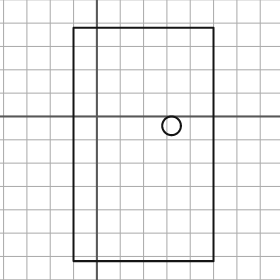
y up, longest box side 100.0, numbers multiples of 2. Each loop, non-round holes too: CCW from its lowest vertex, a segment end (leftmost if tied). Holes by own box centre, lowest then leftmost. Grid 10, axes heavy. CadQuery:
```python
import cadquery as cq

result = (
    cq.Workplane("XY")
    .moveTo(-10.0, -62.0)
    .lineTo(50.0, -62.0)
    .lineTo(50.0, 38.0)
    .lineTo(-10.0, 38.0)
    .close()
    .moveTo(32.0, -4.0)
    .circle(4.0)
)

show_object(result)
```